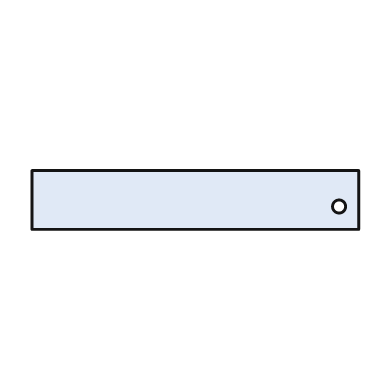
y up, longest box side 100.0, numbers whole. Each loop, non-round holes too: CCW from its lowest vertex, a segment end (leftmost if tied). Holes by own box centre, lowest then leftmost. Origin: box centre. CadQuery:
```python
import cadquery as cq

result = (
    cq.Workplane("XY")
    .moveTo(-50.0, -9.0)
    .lineTo(50.0, -9.0)
    .lineTo(50.0, 9.0)
    .lineTo(-50.0, 9.0)
    .close()
    .moveTo(44.0, -2.0)
    .circle(2.0)
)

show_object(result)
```